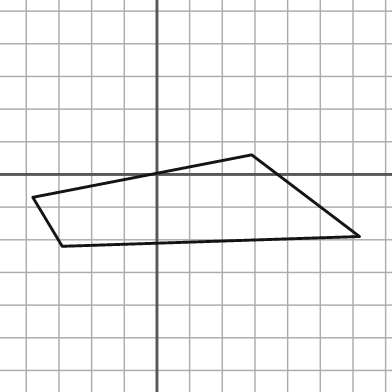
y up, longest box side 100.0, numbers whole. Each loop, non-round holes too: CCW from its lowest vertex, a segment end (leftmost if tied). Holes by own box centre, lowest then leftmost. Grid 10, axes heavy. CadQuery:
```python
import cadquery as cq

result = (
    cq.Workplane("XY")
    .moveTo(-29.0, -22.0)
    .lineTo(62.0, -19.0)
    .lineTo(29.0, 6.0)
    .lineTo(-38.0, -7.0)
    .close()
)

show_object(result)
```